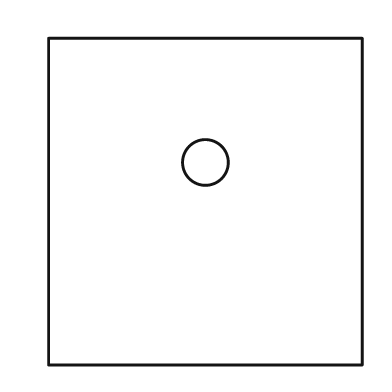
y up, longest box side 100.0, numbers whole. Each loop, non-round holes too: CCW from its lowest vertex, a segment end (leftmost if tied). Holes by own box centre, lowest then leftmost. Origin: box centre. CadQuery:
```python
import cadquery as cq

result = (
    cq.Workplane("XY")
    .moveTo(-48.0, -50.0)
    .lineTo(48.0, -50.0)
    .lineTo(48.0, 50.0)
    .lineTo(-48.0, 50.0)
    .close()
    .moveTo(0.0, 12.0)
    .circle(7.0)
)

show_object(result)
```